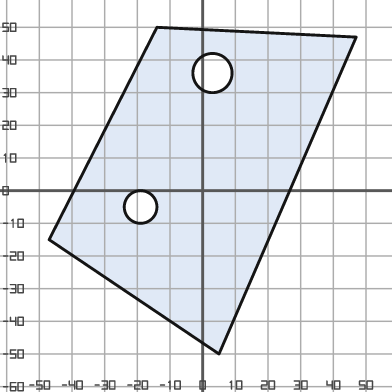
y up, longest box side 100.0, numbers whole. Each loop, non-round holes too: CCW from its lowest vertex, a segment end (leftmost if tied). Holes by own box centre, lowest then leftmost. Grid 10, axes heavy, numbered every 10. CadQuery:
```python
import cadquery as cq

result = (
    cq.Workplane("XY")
    .moveTo(5.0, -50.0)
    .lineTo(47.0, 47.0)
    .lineTo(-14.0, 50.0)
    .lineTo(-47.0, -15.0)
    .close()
    .moveTo(-19.0, -5.0)
    .circle(5.0)
    .moveTo(3.0, 36.0)
    .circle(6.0)
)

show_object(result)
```